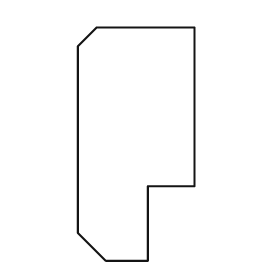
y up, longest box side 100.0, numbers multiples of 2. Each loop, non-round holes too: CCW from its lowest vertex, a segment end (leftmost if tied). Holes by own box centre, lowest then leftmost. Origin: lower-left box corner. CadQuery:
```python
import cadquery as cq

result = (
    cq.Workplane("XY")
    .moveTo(12.0, 0.0)
    .lineTo(30.0, 0.0)
    .lineTo(30.0, 32.0)
    .lineTo(50.0, 32.0)
    .lineTo(50.0, 100.0)
    .lineTo(8.0, 100.0)
    .lineTo(0.0, 92.0)
    .lineTo(0.0, 12.0)
    .close()
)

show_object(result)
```